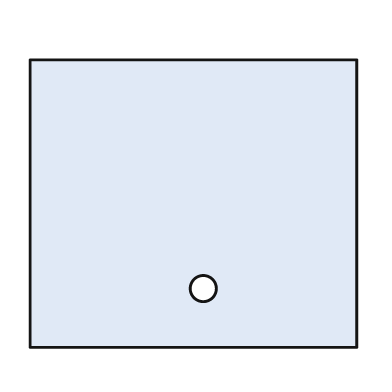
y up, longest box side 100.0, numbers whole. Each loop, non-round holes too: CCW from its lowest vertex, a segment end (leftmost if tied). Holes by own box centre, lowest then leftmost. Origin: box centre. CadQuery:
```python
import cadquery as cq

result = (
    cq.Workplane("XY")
    .moveTo(-50.0, -44.0)
    .lineTo(50.0, -44.0)
    .lineTo(50.0, 44.0)
    .lineTo(-50.0, 44.0)
    .close()
    .moveTo(3.0, -26.0)
    .circle(4.0)
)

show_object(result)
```